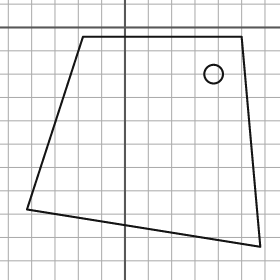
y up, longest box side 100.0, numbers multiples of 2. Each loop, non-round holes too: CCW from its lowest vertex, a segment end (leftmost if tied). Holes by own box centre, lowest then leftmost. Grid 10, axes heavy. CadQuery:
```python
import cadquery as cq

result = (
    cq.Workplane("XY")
    .moveTo(58.0, -94.0)
    .lineTo(50.0, -4.0)
    .lineTo(-18.0, -4.0)
    .lineTo(-42.0, -78.0)
    .close()
    .moveTo(38.0, -20.0)
    .circle(4.0)
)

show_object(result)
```